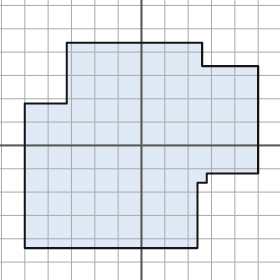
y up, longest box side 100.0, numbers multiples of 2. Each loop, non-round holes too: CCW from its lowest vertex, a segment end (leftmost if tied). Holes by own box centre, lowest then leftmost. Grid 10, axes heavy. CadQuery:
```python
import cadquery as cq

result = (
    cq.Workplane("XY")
    .moveTo(-50.0, -44.0)
    .lineTo(24.0, -44.0)
    .lineTo(24.0, -16.0)
    .lineTo(28.0, -16.0)
    .lineTo(28.0, -12.0)
    .lineTo(50.0, -12.0)
    .lineTo(50.0, 34.0)
    .lineTo(26.0, 34.0)
    .lineTo(26.0, 44.0)
    .lineTo(-32.0, 44.0)
    .lineTo(-32.0, 18.0)
    .lineTo(-50.0, 18.0)
    .close()
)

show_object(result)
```